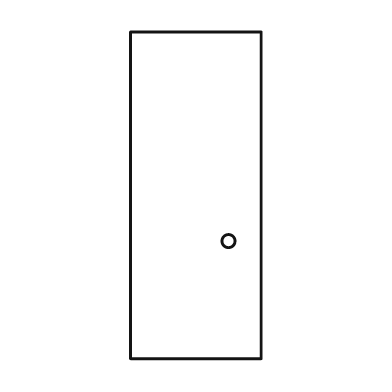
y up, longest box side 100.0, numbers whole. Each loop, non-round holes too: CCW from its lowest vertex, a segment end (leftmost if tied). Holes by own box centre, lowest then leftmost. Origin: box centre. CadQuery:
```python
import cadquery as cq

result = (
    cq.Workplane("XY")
    .moveTo(-20.0, -50.0)
    .lineTo(20.0, -50.0)
    .lineTo(20.0, 50.0)
    .lineTo(-20.0, 50.0)
    .close()
    .moveTo(10.0, -14.0)
    .circle(2.0)
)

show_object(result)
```